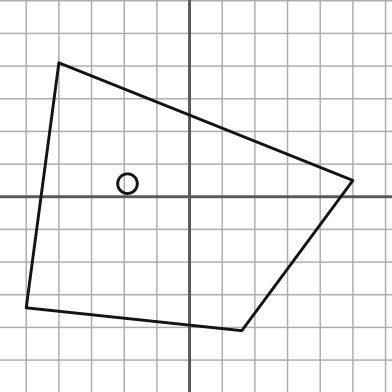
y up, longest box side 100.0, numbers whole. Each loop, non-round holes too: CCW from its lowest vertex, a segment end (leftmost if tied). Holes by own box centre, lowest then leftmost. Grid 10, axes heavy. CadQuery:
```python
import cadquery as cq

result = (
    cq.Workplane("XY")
    .moveTo(16.0, -41.0)
    .lineTo(50.0, 5.0)
    .lineTo(-40.0, 41.0)
    .lineTo(-50.0, -34.0)
    .close()
    .moveTo(-19.0, 4.0)
    .circle(3.0)
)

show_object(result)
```